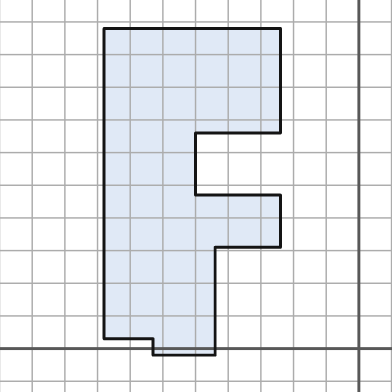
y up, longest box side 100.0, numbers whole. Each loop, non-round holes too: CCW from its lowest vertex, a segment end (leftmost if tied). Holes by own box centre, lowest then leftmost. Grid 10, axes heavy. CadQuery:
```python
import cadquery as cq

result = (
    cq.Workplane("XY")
    .moveTo(-63.0, -2.0)
    .lineTo(-44.0, -2.0)
    .lineTo(-44.0, 31.0)
    .lineTo(-24.0, 31.0)
    .lineTo(-24.0, 47.0)
    .lineTo(-50.0, 47.0)
    .lineTo(-50.0, 66.0)
    .lineTo(-24.0, 66.0)
    .lineTo(-24.0, 98.0)
    .lineTo(-78.0, 98.0)
    .lineTo(-78.0, 3.0)
    .lineTo(-63.0, 3.0)
    .close()
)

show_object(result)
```